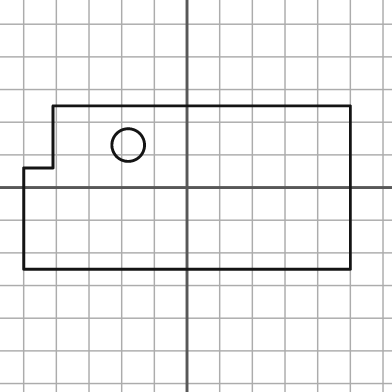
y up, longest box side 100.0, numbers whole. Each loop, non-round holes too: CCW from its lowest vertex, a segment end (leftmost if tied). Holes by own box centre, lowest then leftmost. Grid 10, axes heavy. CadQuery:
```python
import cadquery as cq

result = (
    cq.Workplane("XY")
    .moveTo(-50.0, -25.0)
    .lineTo(50.0, -25.0)
    .lineTo(50.0, 25.0)
    .lineTo(-41.0, 25.0)
    .lineTo(-41.0, 6.0)
    .lineTo(-50.0, 6.0)
    .close()
    .moveTo(-18.0, 13.0)
    .circle(5.0)
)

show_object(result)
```